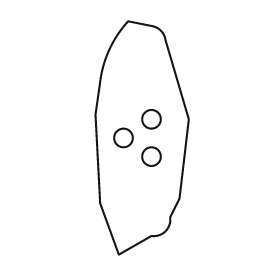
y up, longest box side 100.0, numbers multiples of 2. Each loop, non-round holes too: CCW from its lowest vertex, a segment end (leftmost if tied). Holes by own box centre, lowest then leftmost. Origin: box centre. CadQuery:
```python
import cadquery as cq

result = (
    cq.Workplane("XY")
    .moveTo(-10.0, -50.0)
    .lineTo(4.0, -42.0)
    .threePointArc((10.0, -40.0), (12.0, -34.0))
    .lineTo(16.0, -26.0)
    .lineTo(20.0, 8.0)
    .lineTo(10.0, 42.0)
    .threePointArc((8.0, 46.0), (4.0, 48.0))
    .lineTo(-6.0, 50.0)
    .threePointArc((-14.0, 38.0), (-18.0, 24.0))
    .lineTo(-20.0, 10.0)
    .lineTo(-18.0, -28.0)
    .close()
    .moveTo(4.0, -8.0)
    .circle(4.0)
    .moveTo(-8.0, 0.0)
    .circle(4.0)
    .moveTo(4.0, 8.0)
    .circle(4.0)
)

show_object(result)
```